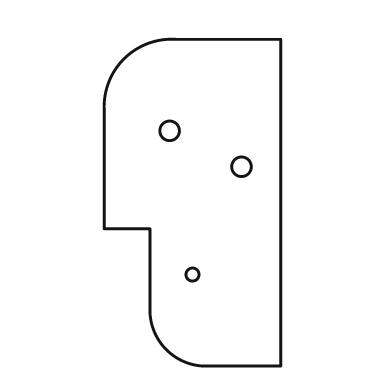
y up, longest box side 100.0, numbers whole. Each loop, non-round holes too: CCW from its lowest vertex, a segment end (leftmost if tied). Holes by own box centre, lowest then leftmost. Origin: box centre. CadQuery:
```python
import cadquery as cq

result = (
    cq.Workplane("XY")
    .moveTo(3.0, -50.0)
    .lineTo(27.0, -50.0)
    .lineTo(27.0, 50.0)
    .lineTo(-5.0, 50.0)
    .threePointArc((-21.0, 44.0), (-27.0, 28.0))
    .lineTo(-27.0, -8.0)
    .lineTo(-13.0, -8.0)
    .lineTo(-13.0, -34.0)
    .threePointArc((-8.0, -45.0), (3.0, -50.0))
    .close()
    .moveTo(0.0, -22.0)
    .circle(2.0)
    .moveTo(15.0, 11.0)
    .circle(3.0)
    .moveTo(-7.0, 22.0)
    .circle(3.0)
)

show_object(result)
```